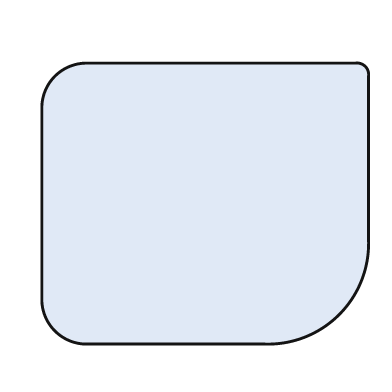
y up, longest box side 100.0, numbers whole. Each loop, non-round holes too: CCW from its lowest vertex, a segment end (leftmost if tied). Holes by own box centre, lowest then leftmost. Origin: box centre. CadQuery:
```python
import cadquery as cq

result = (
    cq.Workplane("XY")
    .moveTo(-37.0, -43.0)
    .lineTo(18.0, -43.0)
    .threePointArc((41.0, -34.0), (50.0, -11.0))
    .lineTo(50.0, 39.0)
    .threePointArc((49.0, 42.0), (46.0, 43.0))
    .lineTo(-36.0, 43.0)
    .threePointArc((-46.0, 39.0), (-50.0, 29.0))
    .lineTo(-50.0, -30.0)
    .threePointArc((-46.0, -39.0), (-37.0, -43.0))
    .close()
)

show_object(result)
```